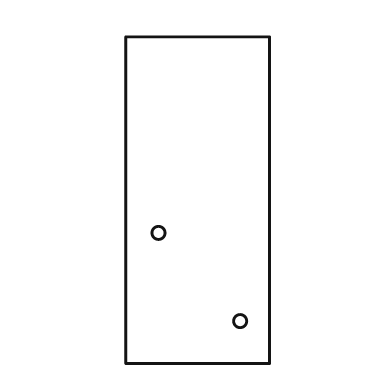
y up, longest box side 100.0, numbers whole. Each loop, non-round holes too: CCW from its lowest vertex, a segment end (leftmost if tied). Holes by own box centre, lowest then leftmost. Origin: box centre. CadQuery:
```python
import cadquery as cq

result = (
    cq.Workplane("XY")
    .moveTo(-22.0, -50.0)
    .lineTo(22.0, -50.0)
    .lineTo(22.0, 50.0)
    .lineTo(-22.0, 50.0)
    .close()
    .moveTo(13.0, -37.0)
    .circle(2.0)
    .moveTo(-12.0, -10.0)
    .circle(2.0)
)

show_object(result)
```